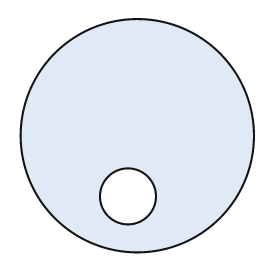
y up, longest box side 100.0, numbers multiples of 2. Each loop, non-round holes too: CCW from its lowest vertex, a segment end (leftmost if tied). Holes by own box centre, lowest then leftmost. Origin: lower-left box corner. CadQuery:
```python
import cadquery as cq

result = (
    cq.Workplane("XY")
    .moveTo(50.0, 50.0)
    .circle(50.0)
    .moveTo(46.0, 24.0)
    .circle(12.0)
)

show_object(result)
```